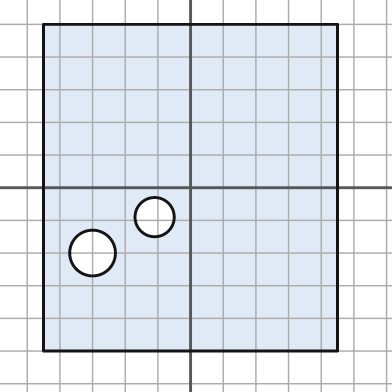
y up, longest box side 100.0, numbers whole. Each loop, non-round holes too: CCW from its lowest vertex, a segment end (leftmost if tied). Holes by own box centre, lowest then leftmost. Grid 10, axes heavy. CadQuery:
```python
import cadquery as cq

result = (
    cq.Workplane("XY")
    .moveTo(-45.0, -50.0)
    .lineTo(45.0, -50.0)
    .lineTo(45.0, 50.0)
    .lineTo(-45.0, 50.0)
    .close()
    .moveTo(-30.0, -20.0)
    .circle(7.0)
    .moveTo(-11.0, -9.0)
    .circle(6.0)
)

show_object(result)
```